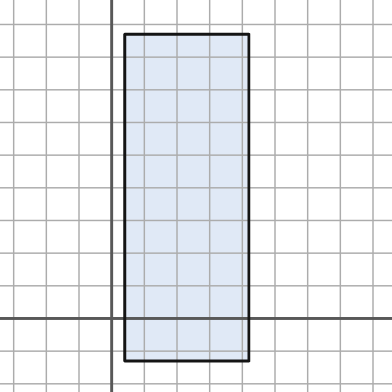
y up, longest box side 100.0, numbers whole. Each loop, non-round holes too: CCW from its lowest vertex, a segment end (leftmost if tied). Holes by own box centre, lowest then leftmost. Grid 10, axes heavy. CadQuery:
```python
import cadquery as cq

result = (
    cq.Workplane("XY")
    .moveTo(4.0, -13.0)
    .lineTo(42.0, -13.0)
    .lineTo(42.0, 87.0)
    .lineTo(4.0, 87.0)
    .close()
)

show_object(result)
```